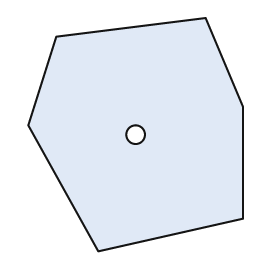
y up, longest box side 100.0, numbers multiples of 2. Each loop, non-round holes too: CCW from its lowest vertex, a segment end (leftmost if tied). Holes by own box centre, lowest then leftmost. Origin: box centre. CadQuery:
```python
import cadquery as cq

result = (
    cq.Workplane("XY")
    .moveTo(-16.0, -50.0)
    .lineTo(46.0, -36.0)
    .lineTo(46.0, 12.0)
    .lineTo(30.0, 50.0)
    .lineTo(-34.0, 42.0)
    .lineTo(-46.0, 4.0)
    .close()
    .moveTo(0.0, 0.0)
    .circle(4.0)
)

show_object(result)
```